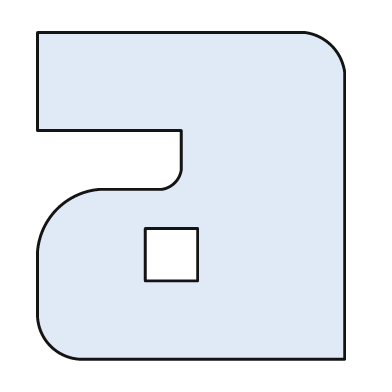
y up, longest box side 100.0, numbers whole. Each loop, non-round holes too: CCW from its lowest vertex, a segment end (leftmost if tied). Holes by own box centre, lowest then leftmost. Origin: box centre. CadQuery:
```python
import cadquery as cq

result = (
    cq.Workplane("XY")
    .moveTo(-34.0, -50.0)
    .lineTo(47.0, -50.0)
    .lineTo(47.0, 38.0)
    .threePointArc((43.0, 46.0), (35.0, 50.0))
    .lineTo(-47.0, 50.0)
    .lineTo(-47.0, 20.0)
    .lineTo(-3.0, 20.0)
    .lineTo(-3.0, 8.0)
    .threePointArc((-5.0, 4.0), (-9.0, 2.0))
    .lineTo(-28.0, 2.0)
    .threePointArc((-41.0, -4.0), (-47.0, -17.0))
    .lineTo(-47.0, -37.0)
    .threePointArc((-43.0, -46.0), (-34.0, -50.0))
    .close()
    .moveTo(-14.0, -26.0)
    .lineTo(2.0, -26.0)
    .lineTo(2.0, -10.0)
    .lineTo(-14.0, -10.0)
    .close()
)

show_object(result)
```